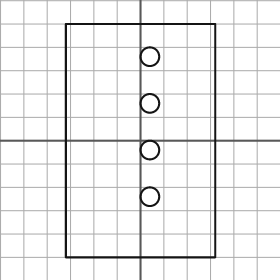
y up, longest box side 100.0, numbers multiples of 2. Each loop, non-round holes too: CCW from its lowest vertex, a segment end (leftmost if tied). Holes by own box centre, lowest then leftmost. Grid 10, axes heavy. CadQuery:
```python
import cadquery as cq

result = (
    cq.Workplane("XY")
    .moveTo(-32.0, -50.0)
    .lineTo(32.0, -50.0)
    .lineTo(32.0, 50.0)
    .lineTo(-32.0, 50.0)
    .close()
    .moveTo(4.0, -24.0)
    .circle(4.0)
    .moveTo(4.0, -4.0)
    .circle(4.0)
    .moveTo(4.0, 16.0)
    .circle(4.0)
    .moveTo(4.0, 36.0)
    .circle(4.0)
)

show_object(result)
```